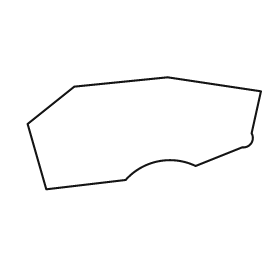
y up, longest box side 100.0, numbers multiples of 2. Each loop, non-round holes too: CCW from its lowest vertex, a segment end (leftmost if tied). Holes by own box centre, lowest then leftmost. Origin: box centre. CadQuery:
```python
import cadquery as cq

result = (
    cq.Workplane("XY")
    .moveTo(-42.0, -24.0)
    .lineTo(-8.0, -20.0)
    .threePointArc((6.0, -12.0), (22.0, -14.0))
    .lineTo(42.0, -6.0)
    .threePointArc((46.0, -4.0), (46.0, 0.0))
    .lineTo(50.0, 18.0)
    .lineTo(10.0, 24.0)
    .lineTo(-30.0, 20.0)
    .lineTo(-50.0, 4.0)
    .close()
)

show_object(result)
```